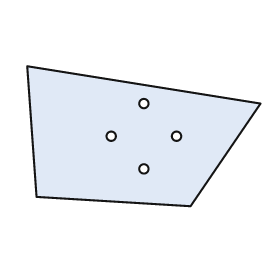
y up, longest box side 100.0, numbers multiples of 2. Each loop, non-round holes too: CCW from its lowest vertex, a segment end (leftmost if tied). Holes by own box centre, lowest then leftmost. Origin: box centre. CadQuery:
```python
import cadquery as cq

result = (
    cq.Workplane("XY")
    .moveTo(20.0, -30.0)
    .lineTo(50.0, 14.0)
    .lineTo(-50.0, 30.0)
    .lineTo(-46.0, -26.0)
    .close()
    .moveTo(0.0, -14.0)
    .circle(2.0)
    .moveTo(-14.0, 0.0)
    .circle(2.0)
    .moveTo(14.0, 0.0)
    .circle(2.0)
    .moveTo(0.0, 14.0)
    .circle(2.0)
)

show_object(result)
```